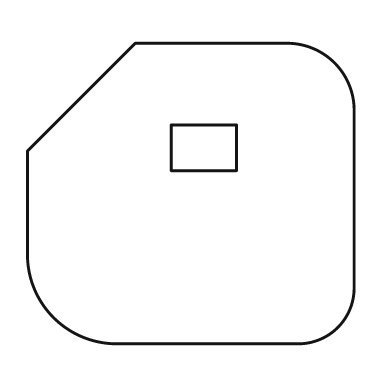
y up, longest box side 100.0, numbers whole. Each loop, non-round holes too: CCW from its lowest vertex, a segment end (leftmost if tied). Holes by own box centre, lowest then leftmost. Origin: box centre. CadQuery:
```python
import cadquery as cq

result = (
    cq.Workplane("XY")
    .moveTo(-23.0, -46.0)
    .lineTo(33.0, -46.0)
    .threePointArc((45.0, -41.0), (50.0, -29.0))
    .lineTo(50.0, 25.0)
    .threePointArc((44.0, 40.0), (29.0, 46.0))
    .lineTo(-17.0, 46.0)
    .lineTo(-50.0, 13.0)
    .lineTo(-50.0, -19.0)
    .threePointArc((-42.0, -38.0), (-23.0, -46.0))
    .close()
    .moveTo(-6.0, 7.0)
    .lineTo(14.0, 7.0)
    .lineTo(14.0, 21.0)
    .lineTo(-6.0, 21.0)
    .close()
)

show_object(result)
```